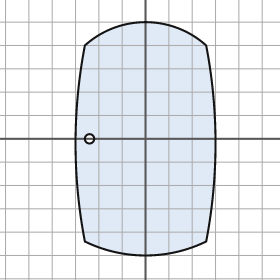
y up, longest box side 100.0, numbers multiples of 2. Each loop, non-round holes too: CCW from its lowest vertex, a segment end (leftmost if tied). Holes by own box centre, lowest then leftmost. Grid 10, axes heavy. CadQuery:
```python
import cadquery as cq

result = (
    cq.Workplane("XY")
    .moveTo(-26.0, -44.0)
    .threePointArc((0.0, -50.0), (26.0, -44.0))
    .threePointArc((30.0, -2.0), (26.0, 40.0))
    .threePointArc((0.0, 50.0), (-26.0, 40.0))
    .threePointArc((-30.0, -2.0), (-26.0, -44.0))
    .close()
    .moveTo(-24.0, 0.0)
    .circle(2.0)
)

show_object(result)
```